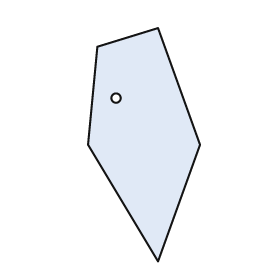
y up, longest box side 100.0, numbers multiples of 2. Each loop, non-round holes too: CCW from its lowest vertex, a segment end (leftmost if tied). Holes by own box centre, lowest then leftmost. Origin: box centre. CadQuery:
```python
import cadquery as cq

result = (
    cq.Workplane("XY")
    .moveTo(6.0, -50.0)
    .lineTo(24.0, 0.0)
    .lineTo(6.0, 50.0)
    .lineTo(-20.0, 42.0)
    .lineTo(-24.0, 0.0)
    .close()
    .moveTo(-12.0, 20.0)
    .circle(2.0)
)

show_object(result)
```